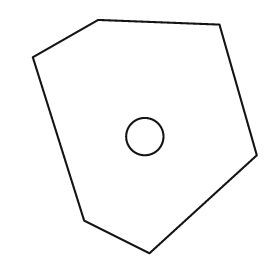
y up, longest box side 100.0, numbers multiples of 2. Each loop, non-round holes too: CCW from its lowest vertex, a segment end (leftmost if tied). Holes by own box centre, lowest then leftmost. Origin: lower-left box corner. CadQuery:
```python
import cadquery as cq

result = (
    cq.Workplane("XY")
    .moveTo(50.0, 0.0)
    .lineTo(96.0, 42.0)
    .lineTo(80.0, 98.0)
    .lineTo(28.0, 100.0)
    .lineTo(0.0, 84.0)
    .lineTo(22.0, 14.0)
    .close()
    .moveTo(48.0, 50.0)
    .circle(8.0)
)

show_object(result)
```